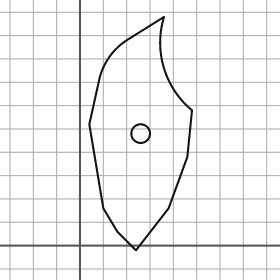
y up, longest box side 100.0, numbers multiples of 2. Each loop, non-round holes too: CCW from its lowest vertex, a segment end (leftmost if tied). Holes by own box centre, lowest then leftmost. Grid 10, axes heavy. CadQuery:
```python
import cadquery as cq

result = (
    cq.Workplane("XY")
    .moveTo(24.0, -2.0)
    .lineTo(38.0, 16.0)
    .lineTo(46.0, 38.0)
    .lineTo(48.0, 58.0)
    .threePointArc((36.0, 76.0), (36.0, 98.0))
    .lineTo(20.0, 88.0)
    .threePointArc((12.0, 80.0), (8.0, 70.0))
    .lineTo(4.0, 52.0)
    .lineTo(10.0, 16.0)
    .lineTo(16.0, 6.0)
    .close()
    .moveTo(26.0, 48.0)
    .circle(4.0)
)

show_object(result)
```